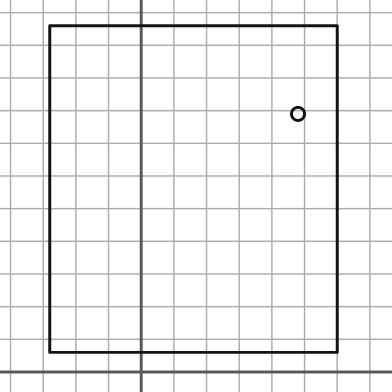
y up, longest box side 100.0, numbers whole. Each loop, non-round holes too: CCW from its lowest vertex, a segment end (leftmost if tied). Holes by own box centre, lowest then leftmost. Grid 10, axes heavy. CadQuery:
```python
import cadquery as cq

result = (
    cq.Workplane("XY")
    .moveTo(-28.0, 6.0)
    .lineTo(60.0, 6.0)
    .lineTo(60.0, 106.0)
    .lineTo(-28.0, 106.0)
    .close()
    .moveTo(48.0, 79.0)
    .circle(2.0)
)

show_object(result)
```